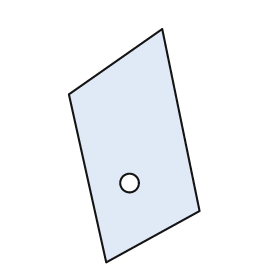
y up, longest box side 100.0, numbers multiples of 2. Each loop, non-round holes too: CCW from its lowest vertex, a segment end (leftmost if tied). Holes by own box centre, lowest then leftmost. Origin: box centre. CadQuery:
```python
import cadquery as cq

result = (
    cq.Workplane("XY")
    .moveTo(-12.0, -50.0)
    .lineTo(28.0, -28.0)
    .lineTo(12.0, 50.0)
    .lineTo(-28.0, 22.0)
    .close()
    .moveTo(-2.0, -16.0)
    .circle(4.0)
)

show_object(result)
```